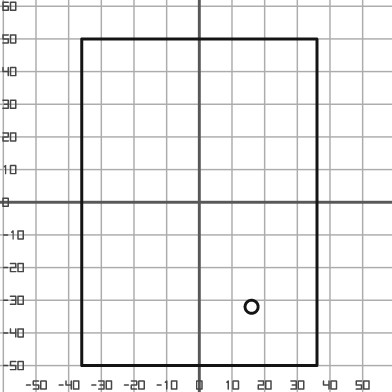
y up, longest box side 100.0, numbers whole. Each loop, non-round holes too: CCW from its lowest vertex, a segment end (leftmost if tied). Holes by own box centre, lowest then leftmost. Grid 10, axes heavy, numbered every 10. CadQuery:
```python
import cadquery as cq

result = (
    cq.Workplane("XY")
    .moveTo(-36.0, -50.0)
    .lineTo(36.0, -50.0)
    .lineTo(36.0, 50.0)
    .lineTo(-36.0, 50.0)
    .close()
    .moveTo(16.0, -32.0)
    .circle(2.0)
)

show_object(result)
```